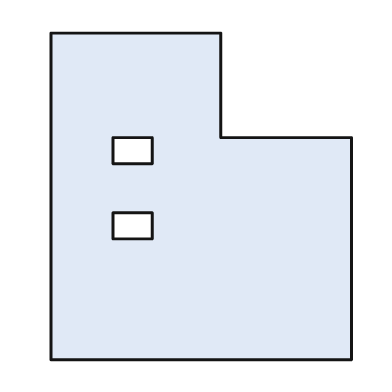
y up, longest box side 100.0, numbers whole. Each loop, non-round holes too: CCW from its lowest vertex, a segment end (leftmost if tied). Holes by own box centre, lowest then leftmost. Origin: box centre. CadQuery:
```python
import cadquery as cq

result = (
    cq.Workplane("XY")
    .moveTo(-46.0, -50.0)
    .lineTo(46.0, -50.0)
    .lineTo(46.0, 18.0)
    .lineTo(6.0, 18.0)
    .lineTo(6.0, 50.0)
    .lineTo(-46.0, 50.0)
    .close()
    .moveTo(-27.0, -13.0)
    .lineTo(-15.0, -13.0)
    .lineTo(-15.0, -5.0)
    .lineTo(-27.0, -5.0)
    .close()
    .moveTo(-27.0, 10.0)
    .lineTo(-15.0, 10.0)
    .lineTo(-15.0, 18.0)
    .lineTo(-27.0, 18.0)
    .close()
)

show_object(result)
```